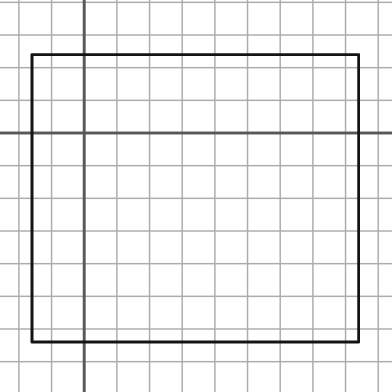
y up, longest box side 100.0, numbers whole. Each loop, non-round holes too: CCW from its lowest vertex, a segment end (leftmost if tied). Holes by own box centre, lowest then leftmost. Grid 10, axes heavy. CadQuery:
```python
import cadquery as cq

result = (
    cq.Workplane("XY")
    .moveTo(-16.0, -64.0)
    .lineTo(84.0, -64.0)
    .lineTo(84.0, 24.0)
    .lineTo(-16.0, 24.0)
    .close()
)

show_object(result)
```